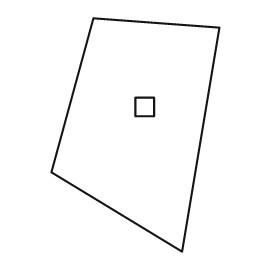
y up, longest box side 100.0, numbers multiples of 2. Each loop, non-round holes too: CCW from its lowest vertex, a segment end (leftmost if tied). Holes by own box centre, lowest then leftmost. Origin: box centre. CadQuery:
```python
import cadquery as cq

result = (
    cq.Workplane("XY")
    .moveTo(20.0, -50.0)
    .lineTo(36.0, 46.0)
    .lineTo(-18.0, 50.0)
    .lineTo(-36.0, -16.0)
    .close()
    .moveTo(0.0, 8.0)
    .lineTo(8.0, 8.0)
    .lineTo(8.0, 16.0)
    .lineTo(0.0, 16.0)
    .close()
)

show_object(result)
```